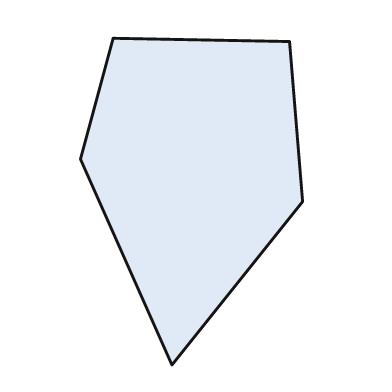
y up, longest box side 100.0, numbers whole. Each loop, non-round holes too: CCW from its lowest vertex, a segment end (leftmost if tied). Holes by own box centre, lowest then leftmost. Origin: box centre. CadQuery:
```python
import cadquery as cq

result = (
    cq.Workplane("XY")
    .moveTo(-6.0, -50.0)
    .lineTo(34.0, 0.0)
    .lineTo(30.0, 49.0)
    .lineTo(-24.0, 50.0)
    .lineTo(-34.0, 13.0)
    .close()
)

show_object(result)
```